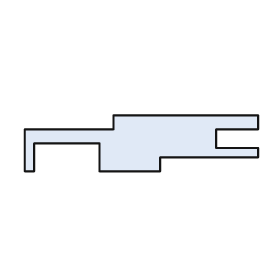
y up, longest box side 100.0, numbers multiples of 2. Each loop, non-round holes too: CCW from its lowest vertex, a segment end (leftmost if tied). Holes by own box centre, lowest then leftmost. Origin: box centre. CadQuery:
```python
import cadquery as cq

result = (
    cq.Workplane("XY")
    .moveTo(-50.0, -12.0)
    .lineTo(-46.0, -12.0)
    .lineTo(-46.0, 0.0)
    .lineTo(-18.0, 0.0)
    .lineTo(-18.0, -12.0)
    .lineTo(8.0, -12.0)
    .lineTo(8.0, -6.0)
    .lineTo(50.0, -6.0)
    .lineTo(50.0, -2.0)
    .lineTo(32.0, -2.0)
    .lineTo(32.0, 6.0)
    .lineTo(50.0, 6.0)
    .lineTo(50.0, 12.0)
    .lineTo(-12.0, 12.0)
    .lineTo(-12.0, 6.0)
    .lineTo(-50.0, 6.0)
    .close()
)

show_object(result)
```